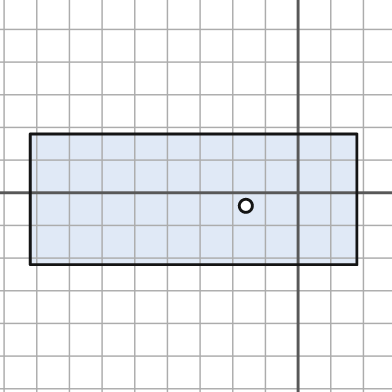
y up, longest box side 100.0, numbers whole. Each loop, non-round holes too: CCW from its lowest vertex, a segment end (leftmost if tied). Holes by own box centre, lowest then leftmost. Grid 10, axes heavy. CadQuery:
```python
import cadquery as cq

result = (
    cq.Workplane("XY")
    .moveTo(-82.0, -22.0)
    .lineTo(18.0, -22.0)
    .lineTo(18.0, 18.0)
    .lineTo(-82.0, 18.0)
    .close()
    .moveTo(-16.0, -4.0)
    .circle(2.0)
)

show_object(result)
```